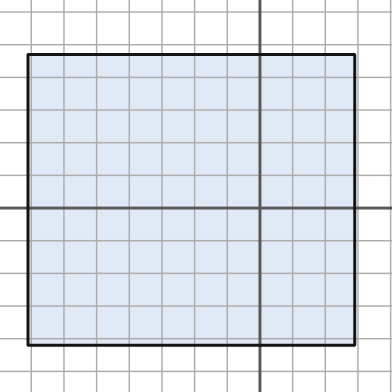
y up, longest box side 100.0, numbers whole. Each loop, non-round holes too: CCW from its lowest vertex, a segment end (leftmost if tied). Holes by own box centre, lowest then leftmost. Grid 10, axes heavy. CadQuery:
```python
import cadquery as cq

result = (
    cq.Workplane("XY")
    .moveTo(-71.0, -42.0)
    .lineTo(29.0, -42.0)
    .lineTo(29.0, 47.0)
    .lineTo(-71.0, 47.0)
    .close()
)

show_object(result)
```